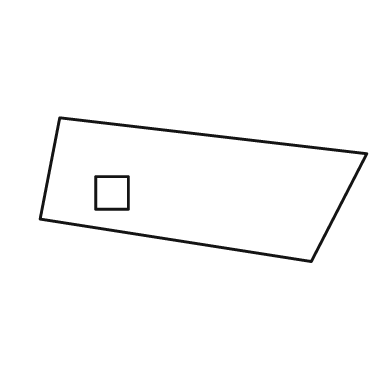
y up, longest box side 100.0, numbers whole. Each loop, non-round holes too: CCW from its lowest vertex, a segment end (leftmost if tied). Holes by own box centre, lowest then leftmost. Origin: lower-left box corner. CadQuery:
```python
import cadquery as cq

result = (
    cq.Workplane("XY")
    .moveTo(83.0, 0.0)
    .lineTo(100.0, 33.0)
    .lineTo(6.0, 44.0)
    .lineTo(0.0, 13.0)
    .close()
    .moveTo(17.0, 16.0)
    .lineTo(27.0, 16.0)
    .lineTo(27.0, 26.0)
    .lineTo(17.0, 26.0)
    .close()
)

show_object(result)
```